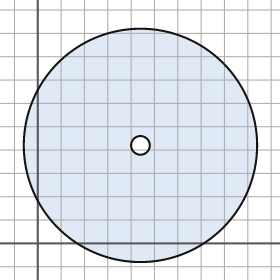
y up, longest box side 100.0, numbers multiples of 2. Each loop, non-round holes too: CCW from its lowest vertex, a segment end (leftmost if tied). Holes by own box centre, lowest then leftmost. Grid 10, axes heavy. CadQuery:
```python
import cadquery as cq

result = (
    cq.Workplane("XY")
    .moveTo(44.0, 42.0)
    .circle(50.0)
    .moveTo(44.0, 42.0)
    .circle(4.0)
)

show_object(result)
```